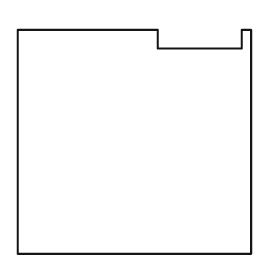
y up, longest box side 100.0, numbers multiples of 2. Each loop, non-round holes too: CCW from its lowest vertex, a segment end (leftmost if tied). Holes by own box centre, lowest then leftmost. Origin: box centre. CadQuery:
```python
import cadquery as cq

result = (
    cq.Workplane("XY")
    .moveTo(-50.0, -48.0)
    .lineTo(50.0, -48.0)
    .lineTo(50.0, 48.0)
    .lineTo(46.0, 48.0)
    .lineTo(46.0, 40.0)
    .lineTo(10.0, 40.0)
    .lineTo(10.0, 48.0)
    .lineTo(-50.0, 48.0)
    .close()
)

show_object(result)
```